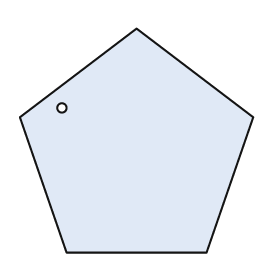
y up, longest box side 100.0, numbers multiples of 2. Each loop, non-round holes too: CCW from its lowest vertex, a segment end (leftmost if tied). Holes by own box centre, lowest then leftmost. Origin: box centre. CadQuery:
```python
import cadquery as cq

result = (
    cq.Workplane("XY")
    .moveTo(-30.0, -48.0)
    .lineTo(30.0, -48.0)
    .lineTo(50.0, 10.0)
    .lineTo(0.0, 48.0)
    .lineTo(-50.0, 10.0)
    .close()
    .moveTo(-32.0, 14.0)
    .circle(2.0)
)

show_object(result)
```